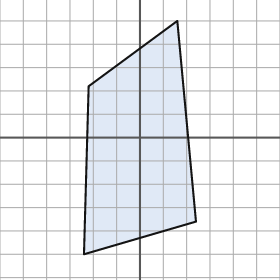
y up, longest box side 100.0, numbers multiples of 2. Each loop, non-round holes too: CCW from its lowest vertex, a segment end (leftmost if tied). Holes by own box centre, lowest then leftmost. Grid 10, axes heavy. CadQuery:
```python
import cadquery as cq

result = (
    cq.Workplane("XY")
    .moveTo(-24.0, -50.0)
    .lineTo(24.0, -36.0)
    .lineTo(16.0, 50.0)
    .lineTo(-22.0, 22.0)
    .close()
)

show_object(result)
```